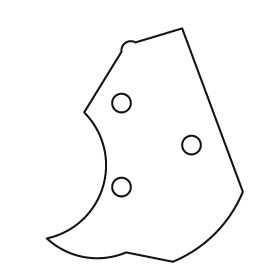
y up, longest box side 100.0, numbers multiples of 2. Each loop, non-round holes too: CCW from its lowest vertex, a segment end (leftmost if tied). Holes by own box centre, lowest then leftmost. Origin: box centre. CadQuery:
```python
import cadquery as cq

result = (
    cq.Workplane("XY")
    .moveTo(12.0, -50.0)
    .threePointArc((30.0, -38.0), (42.0, -20.0))
    .lineTo(16.0, 50.0)
    .lineTo(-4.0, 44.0)
    .threePointArc((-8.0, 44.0), (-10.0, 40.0))
    .lineTo(-26.0, 14.0)
    .threePointArc((-18.0, -18.0), (-42.0, -40.0))
    .threePointArc((-26.0, -48.0), (-8.0, -46.0))
    .close()
    .moveTo(-10.0, -18.0)
    .circle(4.0)
    .moveTo(20.0, 0.0)
    .circle(4.0)
    .moveTo(-10.0, 18.0)
    .circle(4.0)
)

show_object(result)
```